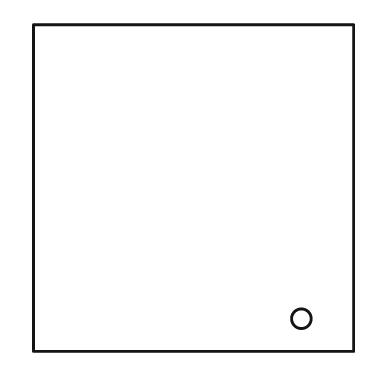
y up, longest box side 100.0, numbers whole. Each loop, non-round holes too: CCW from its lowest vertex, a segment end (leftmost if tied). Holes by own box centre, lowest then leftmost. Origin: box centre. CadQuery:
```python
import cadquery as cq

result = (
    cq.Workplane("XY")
    .moveTo(-49.0, -50.0)
    .lineTo(49.0, -50.0)
    .lineTo(49.0, 50.0)
    .lineTo(-49.0, 50.0)
    .close()
    .moveTo(33.0, -40.0)
    .circle(3.0)
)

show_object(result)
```